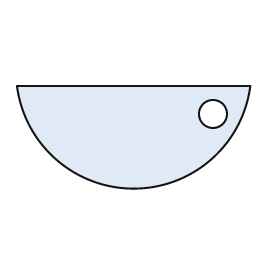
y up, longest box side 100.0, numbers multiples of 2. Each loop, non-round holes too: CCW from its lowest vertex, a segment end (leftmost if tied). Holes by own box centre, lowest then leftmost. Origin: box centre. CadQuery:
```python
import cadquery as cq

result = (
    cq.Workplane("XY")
    .moveTo(-50.0, 22.0)
    .threePointArc((0.0, -22.0), (50.0, 22.0))
    .close()
    .moveTo(34.0, 10.0)
    .circle(6.0)
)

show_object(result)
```